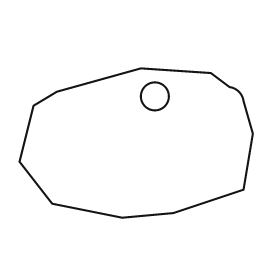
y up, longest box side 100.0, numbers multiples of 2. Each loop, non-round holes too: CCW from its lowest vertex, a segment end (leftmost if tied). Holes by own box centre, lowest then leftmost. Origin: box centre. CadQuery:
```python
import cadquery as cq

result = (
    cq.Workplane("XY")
    .moveTo(-6.0, -32.0)
    .lineTo(16.0, -30.0)
    .lineTo(46.0, -20.0)
    .lineTo(50.0, 4.0)
    .lineTo(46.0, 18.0)
    .threePointArc((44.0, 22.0), (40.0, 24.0))
    .lineTo(32.0, 30.0)
    .lineTo(2.0, 32.0)
    .lineTo(-34.0, 22.0)
    .lineTo(-44.0, 16.0)
    .lineTo(-50.0, -8.0)
    .lineTo(-36.0, -26.0)
    .close()
    .moveTo(8.0, 20.0)
    .circle(6.0)
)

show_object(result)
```